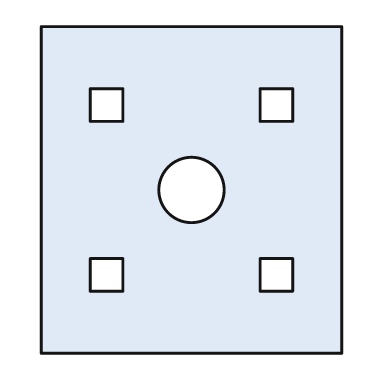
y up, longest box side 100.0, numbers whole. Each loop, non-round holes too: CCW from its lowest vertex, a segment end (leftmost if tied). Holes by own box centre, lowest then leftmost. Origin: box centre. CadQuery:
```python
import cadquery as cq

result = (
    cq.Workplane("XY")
    .moveTo(-46.0, -50.0)
    .lineTo(46.0, -50.0)
    .lineTo(46.0, 50.0)
    .lineTo(-46.0, 50.0)
    .close()
    .moveTo(-31.0, -31.0)
    .lineTo(-21.0, -31.0)
    .lineTo(-21.0, -21.0)
    .lineTo(-31.0, -21.0)
    .close()
    .moveTo(21.0, -31.0)
    .lineTo(31.0, -31.0)
    .lineTo(31.0, -21.0)
    .lineTo(21.0, -21.0)
    .close()
    .moveTo(0.0, 0.0)
    .circle(10.0)
    .moveTo(-31.0, 21.0)
    .lineTo(-21.0, 21.0)
    .lineTo(-21.0, 31.0)
    .lineTo(-31.0, 31.0)
    .close()
    .moveTo(21.0, 21.0)
    .lineTo(31.0, 21.0)
    .lineTo(31.0, 31.0)
    .lineTo(21.0, 31.0)
    .close()
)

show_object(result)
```